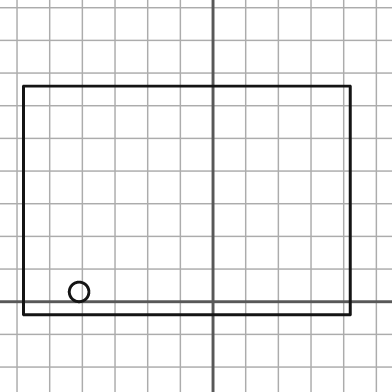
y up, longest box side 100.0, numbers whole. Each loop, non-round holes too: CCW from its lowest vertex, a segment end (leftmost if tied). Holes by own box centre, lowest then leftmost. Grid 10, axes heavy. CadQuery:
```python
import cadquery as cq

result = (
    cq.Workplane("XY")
    .moveTo(-58.0, -4.0)
    .lineTo(42.0, -4.0)
    .lineTo(42.0, 66.0)
    .lineTo(-58.0, 66.0)
    .close()
    .moveTo(-41.0, 3.0)
    .circle(3.0)
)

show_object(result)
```